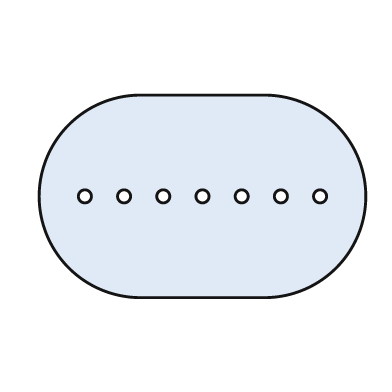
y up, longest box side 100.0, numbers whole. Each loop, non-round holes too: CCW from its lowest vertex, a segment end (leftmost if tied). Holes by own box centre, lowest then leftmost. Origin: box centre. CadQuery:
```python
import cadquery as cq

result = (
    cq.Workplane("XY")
    .moveTo(-19.0, -31.0)
    .lineTo(19.0, -31.0)
    .threePointArc((50.0, 0.0), (19.0, 31.0))
    .lineTo(-19.0, 31.0)
    .threePointArc((-50.0, 0.0), (-19.0, -31.0))
    .close()
    .moveTo(-36.0, 0.0)
    .circle(2.0)
    .moveTo(-24.0, 0.0)
    .circle(2.0)
    .moveTo(-12.0, 0.0)
    .circle(2.0)
    .moveTo(0.0, 0.0)
    .circle(2.0)
    .moveTo(12.0, 0.0)
    .circle(2.0)
    .moveTo(24.0, 0.0)
    .circle(2.0)
    .moveTo(36.0, 0.0)
    .circle(2.0)
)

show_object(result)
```